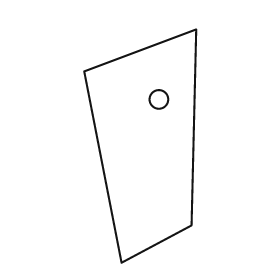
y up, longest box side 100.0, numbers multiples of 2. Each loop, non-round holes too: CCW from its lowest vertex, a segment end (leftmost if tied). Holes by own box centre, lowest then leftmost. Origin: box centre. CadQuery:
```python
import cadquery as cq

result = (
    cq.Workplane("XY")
    .moveTo(-8.0, -50.0)
    .lineTo(22.0, -34.0)
    .lineTo(24.0, 50.0)
    .lineTo(-24.0, 32.0)
    .close()
    .moveTo(8.0, 20.0)
    .circle(4.0)
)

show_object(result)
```